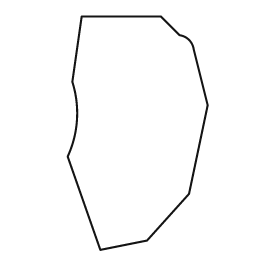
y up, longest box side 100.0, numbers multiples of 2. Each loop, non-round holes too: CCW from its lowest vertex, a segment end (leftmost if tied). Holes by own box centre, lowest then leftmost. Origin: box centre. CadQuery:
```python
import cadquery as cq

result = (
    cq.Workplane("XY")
    .moveTo(-16.0, -50.0)
    .lineTo(4.0, -46.0)
    .lineTo(22.0, -26.0)
    .lineTo(30.0, 12.0)
    .lineTo(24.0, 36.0)
    .threePointArc((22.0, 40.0), (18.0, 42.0))
    .lineTo(10.0, 50.0)
    .lineTo(-24.0, 50.0)
    .lineTo(-28.0, 22.0)
    .threePointArc((-26.0, 6.0), (-30.0, -10.0))
    .close()
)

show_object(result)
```